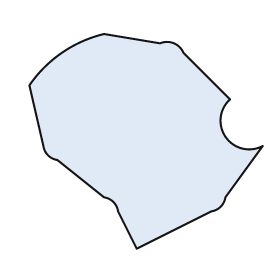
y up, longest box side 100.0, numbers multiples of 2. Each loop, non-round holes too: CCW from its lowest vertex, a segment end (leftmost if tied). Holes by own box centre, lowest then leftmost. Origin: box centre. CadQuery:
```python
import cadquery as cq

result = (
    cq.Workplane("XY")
    .moveTo(-4.0, -46.0)
    .lineTo(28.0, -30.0)
    .threePointArc((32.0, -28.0), (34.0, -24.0))
    .lineTo(50.0, -2.0)
    .threePointArc((34.0, 2.0), (36.0, 18.0))
    .lineTo(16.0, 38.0)
    .threePointArc((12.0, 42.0), (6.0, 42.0))
    .lineTo(-18.0, 46.0)
    .threePointArc((-36.0, 38.0), (-50.0, 24.0))
    .lineTo(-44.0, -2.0)
    .threePointArc((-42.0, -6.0), (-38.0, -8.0))
    .lineTo(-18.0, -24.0)
    .threePointArc((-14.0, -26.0), (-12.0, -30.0))
    .close()
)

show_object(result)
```